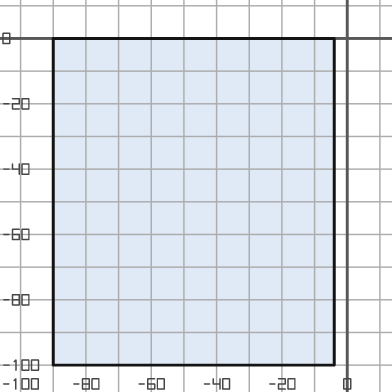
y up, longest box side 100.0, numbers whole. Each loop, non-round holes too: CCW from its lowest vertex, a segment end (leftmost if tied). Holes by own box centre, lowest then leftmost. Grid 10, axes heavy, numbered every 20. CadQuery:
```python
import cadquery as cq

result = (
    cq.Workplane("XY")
    .moveTo(-90.0, -100.0)
    .lineTo(-4.0, -100.0)
    .lineTo(-4.0, 0.0)
    .lineTo(-90.0, 0.0)
    .close()
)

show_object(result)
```